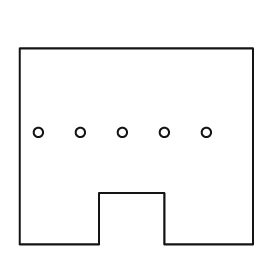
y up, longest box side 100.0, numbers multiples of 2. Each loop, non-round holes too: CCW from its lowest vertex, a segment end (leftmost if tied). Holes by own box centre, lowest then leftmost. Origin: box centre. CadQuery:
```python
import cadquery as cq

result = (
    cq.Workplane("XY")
    .moveTo(-50.0, -42.0)
    .lineTo(-16.0, -42.0)
    .lineTo(-16.0, -20.0)
    .lineTo(12.0, -20.0)
    .lineTo(12.0, -42.0)
    .lineTo(50.0, -42.0)
    .lineTo(50.0, 42.0)
    .lineTo(-50.0, 42.0)
    .close()
    .moveTo(-42.0, 6.0)
    .circle(2.0)
    .moveTo(-24.0, 6.0)
    .circle(2.0)
    .moveTo(-6.0, 6.0)
    .circle(2.0)
    .moveTo(12.0, 6.0)
    .circle(2.0)
    .moveTo(30.0, 6.0)
    .circle(2.0)
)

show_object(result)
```